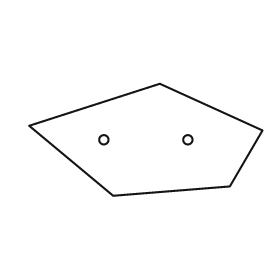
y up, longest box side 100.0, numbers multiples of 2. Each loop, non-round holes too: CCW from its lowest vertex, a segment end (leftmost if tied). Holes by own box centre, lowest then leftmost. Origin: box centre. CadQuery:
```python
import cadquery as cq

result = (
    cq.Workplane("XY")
    .moveTo(-14.0, -24.0)
    .lineTo(36.0, -20.0)
    .lineTo(50.0, 4.0)
    .lineTo(6.0, 24.0)
    .lineTo(-50.0, 6.0)
    .close()
    .moveTo(-18.0, 0.0)
    .circle(2.0)
    .moveTo(18.0, 0.0)
    .circle(2.0)
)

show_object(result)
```